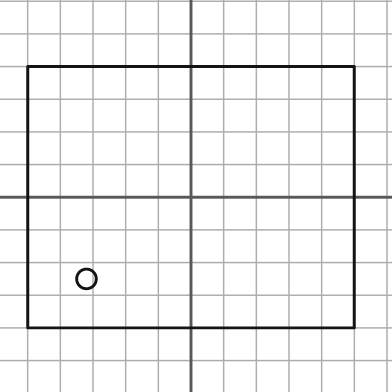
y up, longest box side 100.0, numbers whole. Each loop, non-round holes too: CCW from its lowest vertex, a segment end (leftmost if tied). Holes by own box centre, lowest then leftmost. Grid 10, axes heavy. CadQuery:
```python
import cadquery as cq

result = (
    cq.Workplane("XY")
    .moveTo(-50.0, -40.0)
    .lineTo(50.0, -40.0)
    .lineTo(50.0, 40.0)
    .lineTo(-50.0, 40.0)
    .close()
    .moveTo(-32.0, -25.0)
    .circle(3.0)
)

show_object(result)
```